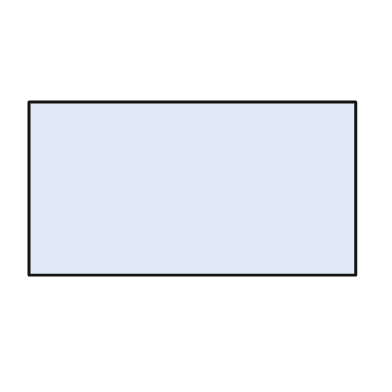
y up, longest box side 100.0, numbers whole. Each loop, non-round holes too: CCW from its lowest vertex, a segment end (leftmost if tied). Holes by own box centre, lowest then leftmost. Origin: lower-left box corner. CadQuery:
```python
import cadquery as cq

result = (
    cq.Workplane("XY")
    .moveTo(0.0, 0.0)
    .lineTo(100.0, 0.0)
    .lineTo(100.0, 53.0)
    .lineTo(0.0, 53.0)
    .close()
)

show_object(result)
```